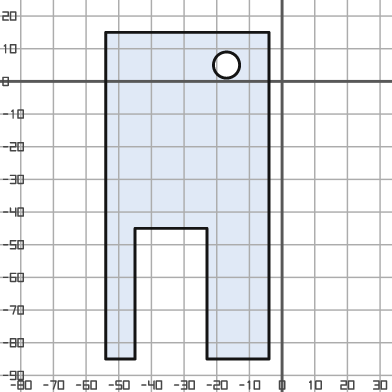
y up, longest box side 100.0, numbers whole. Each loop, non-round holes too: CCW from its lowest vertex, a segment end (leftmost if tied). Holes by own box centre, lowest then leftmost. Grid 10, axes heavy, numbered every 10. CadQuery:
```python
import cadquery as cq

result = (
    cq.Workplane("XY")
    .moveTo(-54.0, -85.0)
    .lineTo(-45.0, -85.0)
    .lineTo(-45.0, -45.0)
    .lineTo(-23.0, -45.0)
    .lineTo(-23.0, -85.0)
    .lineTo(-4.0, -85.0)
    .lineTo(-4.0, 15.0)
    .lineTo(-54.0, 15.0)
    .close()
    .moveTo(-17.0, 5.0)
    .circle(4.0)
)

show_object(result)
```